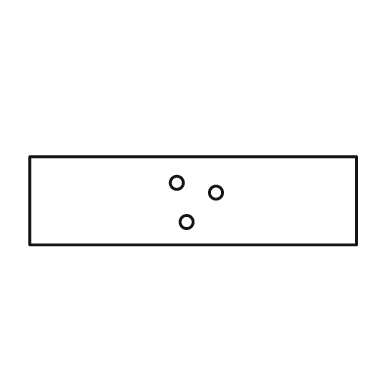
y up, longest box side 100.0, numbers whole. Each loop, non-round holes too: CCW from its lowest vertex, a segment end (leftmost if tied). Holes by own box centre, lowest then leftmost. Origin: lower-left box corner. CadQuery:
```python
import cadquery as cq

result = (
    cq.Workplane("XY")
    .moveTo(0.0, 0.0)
    .lineTo(100.0, 0.0)
    .lineTo(100.0, 27.0)
    .lineTo(0.0, 27.0)
    .close()
    .moveTo(48.0, 7.0)
    .circle(2.0)
    .moveTo(57.0, 16.0)
    .circle(2.0)
    .moveTo(45.0, 19.0)
    .circle(2.0)
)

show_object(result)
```